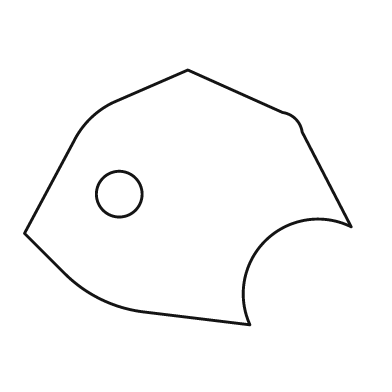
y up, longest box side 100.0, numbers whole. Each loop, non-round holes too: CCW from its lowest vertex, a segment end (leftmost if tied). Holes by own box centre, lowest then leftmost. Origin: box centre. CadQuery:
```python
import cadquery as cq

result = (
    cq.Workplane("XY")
    .moveTo(19.0, -39.0)
    .threePointArc((24.0, -13.0), (50.0, -9.0))
    .lineTo(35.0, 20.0)
    .threePointArc((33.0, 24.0), (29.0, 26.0))
    .lineTo(0.0, 39.0)
    .lineTo(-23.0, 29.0)
    .threePointArc((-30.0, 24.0), (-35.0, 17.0))
    .lineTo(-50.0, -11.0)
    .lineTo(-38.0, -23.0)
    .threePointArc((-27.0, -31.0), (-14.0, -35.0))
    .close()
    .moveTo(-21.0, 1.0)
    .circle(7.0)
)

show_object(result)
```